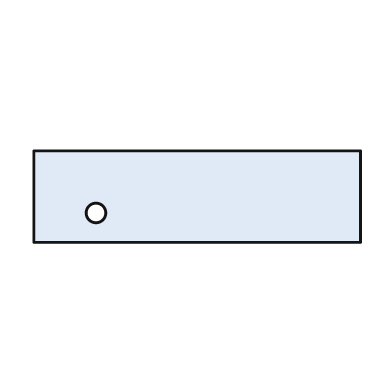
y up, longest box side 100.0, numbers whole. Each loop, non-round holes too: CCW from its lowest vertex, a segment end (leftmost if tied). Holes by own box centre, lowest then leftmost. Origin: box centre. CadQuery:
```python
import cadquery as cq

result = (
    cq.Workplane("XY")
    .moveTo(-50.0, -14.0)
    .lineTo(50.0, -14.0)
    .lineTo(50.0, 14.0)
    .lineTo(-50.0, 14.0)
    .close()
    .moveTo(-31.0, -5.0)
    .circle(3.0)
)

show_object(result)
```